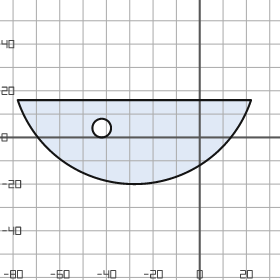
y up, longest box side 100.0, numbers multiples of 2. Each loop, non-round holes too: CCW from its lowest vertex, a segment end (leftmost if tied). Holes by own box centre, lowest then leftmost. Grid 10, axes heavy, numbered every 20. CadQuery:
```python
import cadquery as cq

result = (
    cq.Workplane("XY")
    .moveTo(-78.0, 16.0)
    .threePointArc((-28.0, -20.0), (22.0, 16.0))
    .close()
    .moveTo(-42.0, 4.0)
    .circle(4.0)
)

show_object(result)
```